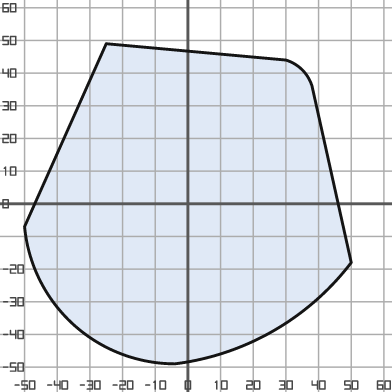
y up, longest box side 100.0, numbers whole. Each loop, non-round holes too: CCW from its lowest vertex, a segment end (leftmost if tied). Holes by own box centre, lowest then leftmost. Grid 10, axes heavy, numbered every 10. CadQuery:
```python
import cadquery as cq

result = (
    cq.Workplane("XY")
    .moveTo(-4.0, -49.0)
    .threePointArc((26.0, -39.0), (50.0, -18.0))
    .lineTo(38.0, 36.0)
    .threePointArc((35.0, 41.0), (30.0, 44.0))
    .lineTo(-25.0, 49.0)
    .lineTo(-50.0, -7.0)
    .threePointArc((-35.0, -37.0), (-4.0, -49.0))
    .close()
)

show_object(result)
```